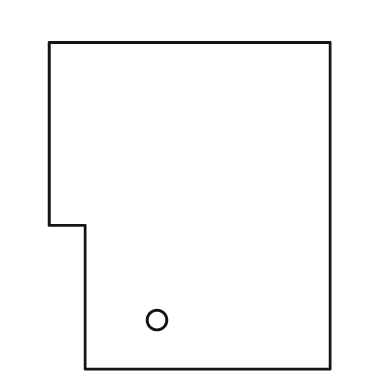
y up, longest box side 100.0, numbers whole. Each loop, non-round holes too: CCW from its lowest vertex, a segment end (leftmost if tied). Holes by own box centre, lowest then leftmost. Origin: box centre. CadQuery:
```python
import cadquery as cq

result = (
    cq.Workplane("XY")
    .moveTo(-32.0, -50.0)
    .lineTo(43.0, -50.0)
    .lineTo(43.0, 50.0)
    .lineTo(-43.0, 50.0)
    .lineTo(-43.0, -6.0)
    .lineTo(-32.0, -6.0)
    .close()
    .moveTo(-10.0, -35.0)
    .circle(3.0)
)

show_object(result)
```